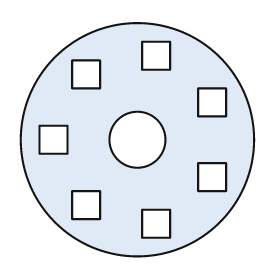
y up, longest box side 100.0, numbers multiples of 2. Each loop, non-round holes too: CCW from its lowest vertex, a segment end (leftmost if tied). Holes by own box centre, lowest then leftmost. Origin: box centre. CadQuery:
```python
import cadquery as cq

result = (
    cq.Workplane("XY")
    .moveTo(0.0, 0.0)
    .circle(50.0)
    .moveTo(2.0, -42.0)
    .lineTo(14.0, -42.0)
    .lineTo(14.0, -30.0)
    .lineTo(2.0, -30.0)
    .close()
    .moveTo(-28.0, -34.0)
    .lineTo(-16.0, -34.0)
    .lineTo(-16.0, -22.0)
    .lineTo(-28.0, -22.0)
    .close()
    .moveTo(26.0, -22.0)
    .lineTo(38.0, -22.0)
    .lineTo(38.0, -10.0)
    .lineTo(26.0, -10.0)
    .close()
    .moveTo(-42.0, -6.0)
    .lineTo(-30.0, -6.0)
    .lineTo(-30.0, 6.0)
    .lineTo(-42.0, 6.0)
    .close()
    .moveTo(0.0, 0.0)
    .circle(12.0)
    .moveTo(26.0, 10.0)
    .lineTo(38.0, 10.0)
    .lineTo(38.0, 22.0)
    .lineTo(26.0, 22.0)
    .close()
    .moveTo(-28.0, 22.0)
    .lineTo(-16.0, 22.0)
    .lineTo(-16.0, 34.0)
    .lineTo(-28.0, 34.0)
    .close()
    .moveTo(2.0, 30.0)
    .lineTo(14.0, 30.0)
    .lineTo(14.0, 42.0)
    .lineTo(2.0, 42.0)
    .close()
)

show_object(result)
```